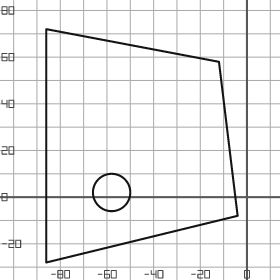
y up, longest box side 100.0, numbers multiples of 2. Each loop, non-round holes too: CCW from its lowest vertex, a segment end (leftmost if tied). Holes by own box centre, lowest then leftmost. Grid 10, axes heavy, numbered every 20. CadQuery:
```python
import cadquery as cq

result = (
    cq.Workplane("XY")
    .moveTo(-86.0, -28.0)
    .lineTo(-4.0, -8.0)
    .lineTo(-12.0, 58.0)
    .lineTo(-86.0, 72.0)
    .close()
    .moveTo(-58.0, 2.0)
    .circle(8.0)
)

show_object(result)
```